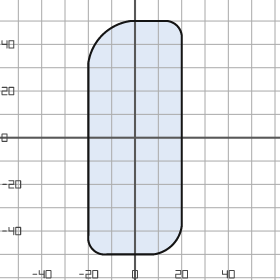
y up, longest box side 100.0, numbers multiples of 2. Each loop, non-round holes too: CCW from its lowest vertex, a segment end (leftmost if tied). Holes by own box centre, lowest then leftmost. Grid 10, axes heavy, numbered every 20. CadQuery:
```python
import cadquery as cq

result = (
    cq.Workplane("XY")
    .moveTo(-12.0, -50.0)
    .lineTo(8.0, -50.0)
    .threePointArc((16.0, -46.0), (20.0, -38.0))
    .lineTo(20.0, 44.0)
    .threePointArc((18.0, 48.0), (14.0, 50.0))
    .lineTo(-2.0, 50.0)
    .threePointArc((-14.0, 44.0), (-20.0, 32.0))
    .lineTo(-20.0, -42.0)
    .threePointArc((-18.0, -48.0), (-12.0, -50.0))
    .close()
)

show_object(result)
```